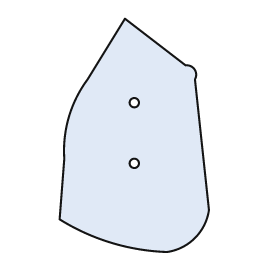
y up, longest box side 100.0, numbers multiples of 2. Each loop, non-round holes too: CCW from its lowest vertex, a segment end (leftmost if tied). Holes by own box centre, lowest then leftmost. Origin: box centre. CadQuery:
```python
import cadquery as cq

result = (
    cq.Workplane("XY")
    .moveTo(14.0, -50.0)
    .threePointArc((26.0, -44.0), (32.0, -32.0))
    .lineTo(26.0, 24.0)
    .threePointArc((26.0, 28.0), (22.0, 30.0))
    .lineTo(-4.0, 50.0)
    .lineTo(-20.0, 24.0)
    .threePointArc((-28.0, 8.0), (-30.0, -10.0))
    .lineTo(-32.0, -36.0)
    .threePointArc((-10.0, -46.0), (14.0, -50.0))
    .close()
    .moveTo(0.0, -12.0)
    .circle(2.0)
    .moveTo(0.0, 14.0)
    .circle(2.0)
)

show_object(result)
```